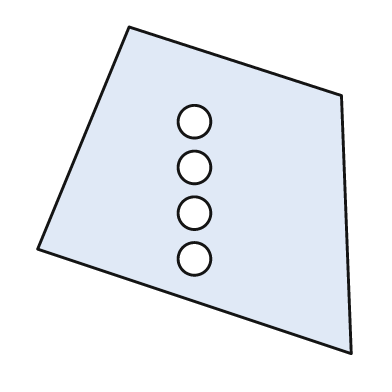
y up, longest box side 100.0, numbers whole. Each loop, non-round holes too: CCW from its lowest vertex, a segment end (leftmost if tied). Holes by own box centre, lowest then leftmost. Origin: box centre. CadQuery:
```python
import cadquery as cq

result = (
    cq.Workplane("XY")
    .moveTo(48.0, -50.0)
    .lineTo(45.0, 29.0)
    .lineTo(-20.0, 50.0)
    .lineTo(-48.0, -18.0)
    .close()
    .moveTo(0.0, -21.0)
    .circle(5.0)
    .moveTo(0.0, -7.0)
    .circle(5.0)
    .moveTo(0.0, 7.0)
    .circle(5.0)
    .moveTo(0.0, 21.0)
    .circle(5.0)
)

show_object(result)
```